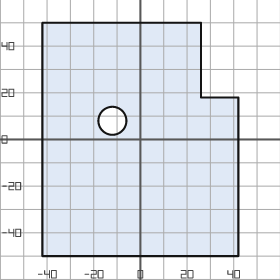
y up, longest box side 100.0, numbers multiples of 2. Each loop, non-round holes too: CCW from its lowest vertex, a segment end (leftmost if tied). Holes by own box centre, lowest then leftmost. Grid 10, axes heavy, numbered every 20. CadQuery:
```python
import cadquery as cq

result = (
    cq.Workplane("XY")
    .moveTo(-42.0, -50.0)
    .lineTo(42.0, -50.0)
    .lineTo(42.0, 18.0)
    .lineTo(26.0, 18.0)
    .lineTo(26.0, 50.0)
    .lineTo(-42.0, 50.0)
    .close()
    .moveTo(-12.0, 8.0)
    .circle(6.0)
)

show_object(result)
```